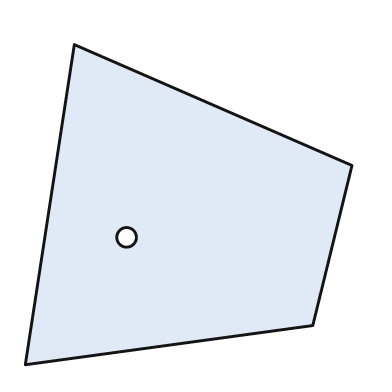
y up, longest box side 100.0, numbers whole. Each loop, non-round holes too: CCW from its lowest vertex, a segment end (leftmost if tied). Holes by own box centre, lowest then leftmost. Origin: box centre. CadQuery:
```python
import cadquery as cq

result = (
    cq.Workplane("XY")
    .moveTo(-50.0, -49.0)
    .lineTo(38.0, -37.0)
    .lineTo(50.0, 12.0)
    .lineTo(-35.0, 49.0)
    .close()
    .moveTo(-19.0, -10.0)
    .circle(3.0)
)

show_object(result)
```